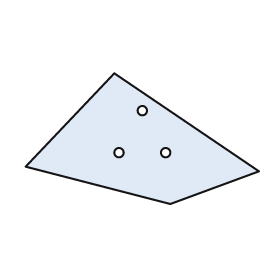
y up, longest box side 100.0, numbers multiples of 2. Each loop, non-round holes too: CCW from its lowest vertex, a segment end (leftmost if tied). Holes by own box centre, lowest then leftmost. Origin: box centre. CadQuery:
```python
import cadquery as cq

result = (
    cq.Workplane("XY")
    .moveTo(12.0, -28.0)
    .lineTo(50.0, -14.0)
    .lineTo(-12.0, 28.0)
    .lineTo(-50.0, -12.0)
    .close()
    .moveTo(-10.0, -6.0)
    .circle(2.0)
    .moveTo(10.0, -6.0)
    .circle(2.0)
    .moveTo(0.0, 12.0)
    .circle(2.0)
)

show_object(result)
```